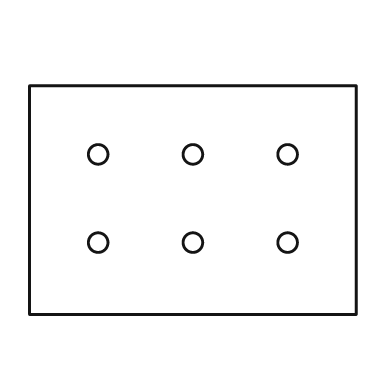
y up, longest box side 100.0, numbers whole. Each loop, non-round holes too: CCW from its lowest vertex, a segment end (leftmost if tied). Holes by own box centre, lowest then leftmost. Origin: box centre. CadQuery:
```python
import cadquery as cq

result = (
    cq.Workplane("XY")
    .moveTo(-50.0, -35.0)
    .lineTo(50.0, -35.0)
    .lineTo(50.0, 35.0)
    .lineTo(-50.0, 35.0)
    .close()
    .moveTo(-29.0, -13.0)
    .circle(3.0)
    .moveTo(0.0, -13.0)
    .circle(3.0)
    .moveTo(29.0, -13.0)
    .circle(3.0)
    .moveTo(-29.0, 14.0)
    .circle(3.0)
    .moveTo(0.0, 14.0)
    .circle(3.0)
    .moveTo(29.0, 14.0)
    .circle(3.0)
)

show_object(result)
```